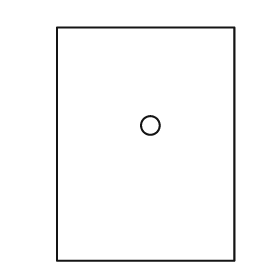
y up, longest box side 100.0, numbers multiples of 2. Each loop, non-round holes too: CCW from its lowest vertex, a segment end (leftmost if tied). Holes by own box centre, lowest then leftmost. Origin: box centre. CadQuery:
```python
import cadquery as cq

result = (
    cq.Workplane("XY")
    .moveTo(-38.0, -50.0)
    .lineTo(38.0, -50.0)
    .lineTo(38.0, 50.0)
    .lineTo(-38.0, 50.0)
    .close()
    .moveTo(2.0, 8.0)
    .circle(4.0)
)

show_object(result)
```